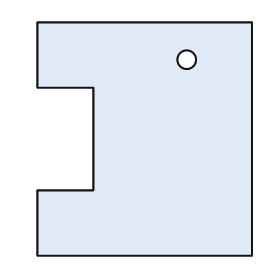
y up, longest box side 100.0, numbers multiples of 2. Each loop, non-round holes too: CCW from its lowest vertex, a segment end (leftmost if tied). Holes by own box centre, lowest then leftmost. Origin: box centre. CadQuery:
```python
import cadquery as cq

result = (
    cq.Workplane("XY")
    .moveTo(-46.0, -50.0)
    .lineTo(46.0, -50.0)
    .lineTo(46.0, 50.0)
    .lineTo(-46.0, 50.0)
    .lineTo(-46.0, 22.0)
    .lineTo(-22.0, 22.0)
    .lineTo(-22.0, -22.0)
    .lineTo(-46.0, -22.0)
    .close()
    .moveTo(18.0, 34.0)
    .circle(4.0)
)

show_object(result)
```